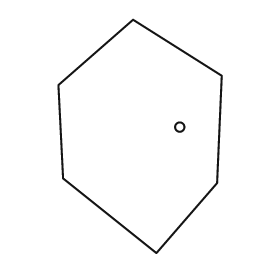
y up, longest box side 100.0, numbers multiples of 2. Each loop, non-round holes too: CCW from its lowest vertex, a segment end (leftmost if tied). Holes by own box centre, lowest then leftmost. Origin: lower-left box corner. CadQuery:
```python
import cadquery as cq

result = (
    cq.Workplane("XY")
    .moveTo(42.0, 0.0)
    .lineTo(68.0, 30.0)
    .lineTo(70.0, 76.0)
    .lineTo(32.0, 100.0)
    .lineTo(0.0, 72.0)
    .lineTo(2.0, 32.0)
    .close()
    .moveTo(52.0, 54.0)
    .circle(2.0)
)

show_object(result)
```